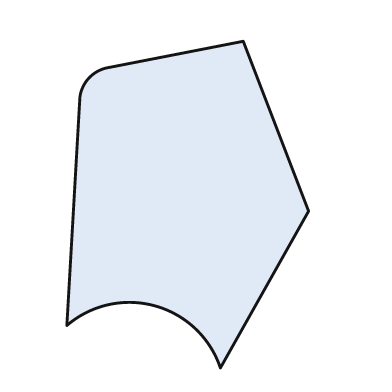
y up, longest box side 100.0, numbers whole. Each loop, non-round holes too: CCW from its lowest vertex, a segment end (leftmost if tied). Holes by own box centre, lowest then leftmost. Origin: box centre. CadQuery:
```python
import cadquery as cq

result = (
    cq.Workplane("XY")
    .moveTo(10.0, -50.0)
    .lineTo(37.0, -2.0)
    .lineTo(17.0, 50.0)
    .lineTo(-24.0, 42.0)
    .threePointArc((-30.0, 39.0), (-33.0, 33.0))
    .lineTo(-37.0, -37.0)
    .threePointArc((-10.0, -31.0), (10.0, -50.0))
    .close()
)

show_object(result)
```